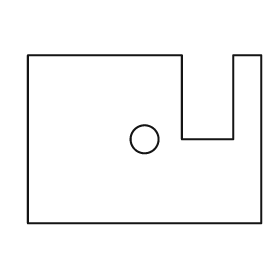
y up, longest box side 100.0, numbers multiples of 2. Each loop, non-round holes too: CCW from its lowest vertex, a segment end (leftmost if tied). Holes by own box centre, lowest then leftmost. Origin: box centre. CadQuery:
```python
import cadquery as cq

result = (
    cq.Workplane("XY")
    .moveTo(-50.0, -36.0)
    .lineTo(50.0, -36.0)
    .lineTo(50.0, 36.0)
    .lineTo(38.0, 36.0)
    .lineTo(38.0, 0.0)
    .lineTo(16.0, 0.0)
    .lineTo(16.0, 36.0)
    .lineTo(-50.0, 36.0)
    .close()
    .moveTo(0.0, 0.0)
    .circle(6.0)
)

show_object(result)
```